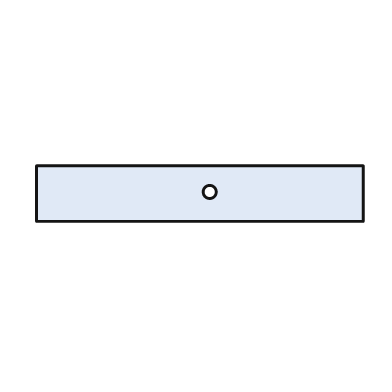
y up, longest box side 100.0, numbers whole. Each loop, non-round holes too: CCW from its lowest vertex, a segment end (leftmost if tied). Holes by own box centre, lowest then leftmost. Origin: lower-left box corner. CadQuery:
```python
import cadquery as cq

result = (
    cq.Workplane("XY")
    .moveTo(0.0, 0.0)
    .lineTo(100.0, 0.0)
    .lineTo(100.0, 17.0)
    .lineTo(0.0, 17.0)
    .close()
    .moveTo(53.0, 9.0)
    .circle(2.0)
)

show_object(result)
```